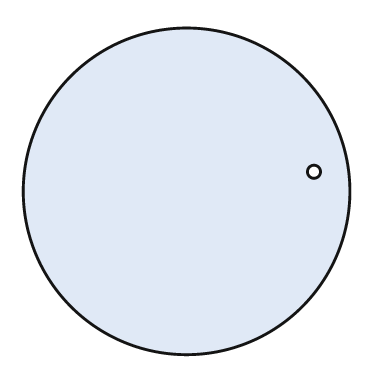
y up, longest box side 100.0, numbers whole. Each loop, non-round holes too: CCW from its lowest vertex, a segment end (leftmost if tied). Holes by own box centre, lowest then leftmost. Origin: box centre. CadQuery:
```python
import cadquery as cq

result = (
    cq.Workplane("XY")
    .moveTo(0.0, 0.0)
    .circle(50.0)
    .moveTo(39.0, 6.0)
    .circle(2.0)
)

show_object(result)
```